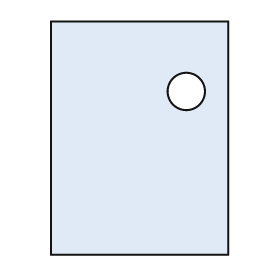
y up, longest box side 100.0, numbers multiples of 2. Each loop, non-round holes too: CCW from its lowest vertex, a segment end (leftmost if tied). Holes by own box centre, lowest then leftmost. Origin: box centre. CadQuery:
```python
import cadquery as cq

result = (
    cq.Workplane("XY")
    .moveTo(-38.0, -50.0)
    .lineTo(38.0, -50.0)
    .lineTo(38.0, 50.0)
    .lineTo(-38.0, 50.0)
    .close()
    .moveTo(20.0, 20.0)
    .circle(8.0)
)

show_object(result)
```